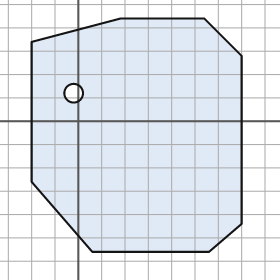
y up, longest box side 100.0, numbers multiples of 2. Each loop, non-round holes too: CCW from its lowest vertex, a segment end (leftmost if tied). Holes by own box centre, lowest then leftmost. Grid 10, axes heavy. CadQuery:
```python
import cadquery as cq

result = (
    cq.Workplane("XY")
    .moveTo(6.0, -56.0)
    .lineTo(56.0, -56.0)
    .lineTo(70.0, -44.0)
    .lineTo(70.0, 28.0)
    .lineTo(54.0, 44.0)
    .lineTo(18.0, 44.0)
    .lineTo(-20.0, 34.0)
    .lineTo(-20.0, -26.0)
    .close()
    .moveTo(-2.0, 12.0)
    .circle(4.0)
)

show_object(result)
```